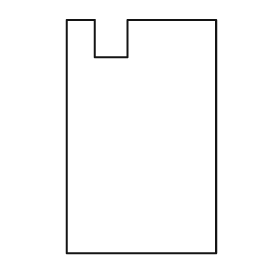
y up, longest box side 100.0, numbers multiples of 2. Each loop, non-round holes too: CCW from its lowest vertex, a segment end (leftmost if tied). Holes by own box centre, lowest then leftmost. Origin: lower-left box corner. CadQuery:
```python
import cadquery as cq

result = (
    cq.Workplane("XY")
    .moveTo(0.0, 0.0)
    .lineTo(64.0, 0.0)
    .lineTo(64.0, 100.0)
    .lineTo(26.0, 100.0)
    .lineTo(26.0, 84.0)
    .lineTo(12.0, 84.0)
    .lineTo(12.0, 100.0)
    .lineTo(0.0, 100.0)
    .close()
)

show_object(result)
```